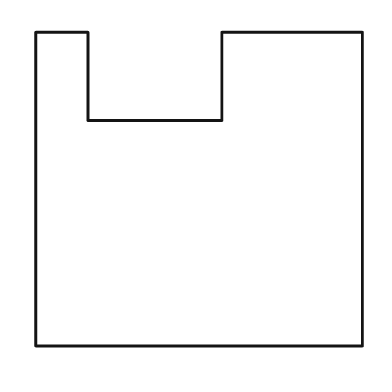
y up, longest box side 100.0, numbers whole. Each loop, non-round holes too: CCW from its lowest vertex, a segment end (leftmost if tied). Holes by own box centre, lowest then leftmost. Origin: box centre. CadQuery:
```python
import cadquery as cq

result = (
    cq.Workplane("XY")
    .moveTo(-50.0, -48.0)
    .lineTo(50.0, -48.0)
    .lineTo(50.0, 48.0)
    .lineTo(7.0, 48.0)
    .lineTo(7.0, 21.0)
    .lineTo(-34.0, 21.0)
    .lineTo(-34.0, 48.0)
    .lineTo(-50.0, 48.0)
    .close()
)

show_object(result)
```